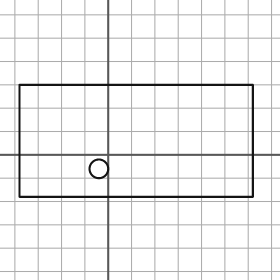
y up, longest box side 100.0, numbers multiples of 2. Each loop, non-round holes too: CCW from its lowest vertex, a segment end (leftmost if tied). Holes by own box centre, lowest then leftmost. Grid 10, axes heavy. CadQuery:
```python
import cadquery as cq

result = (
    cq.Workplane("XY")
    .moveTo(-38.0, -18.0)
    .lineTo(62.0, -18.0)
    .lineTo(62.0, 30.0)
    .lineTo(-38.0, 30.0)
    .close()
    .moveTo(-4.0, -6.0)
    .circle(4.0)
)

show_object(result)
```